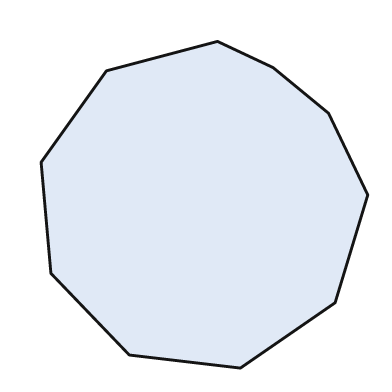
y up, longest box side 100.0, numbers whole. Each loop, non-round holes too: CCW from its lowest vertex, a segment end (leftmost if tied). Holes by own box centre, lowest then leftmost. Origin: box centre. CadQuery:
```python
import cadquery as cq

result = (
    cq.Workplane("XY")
    .moveTo(11.0, -50.0)
    .lineTo(40.0, -30.0)
    .lineTo(50.0, 3.0)
    .lineTo(38.0, 28.0)
    .lineTo(21.0, 42.0)
    .lineTo(4.0, 50.0)
    .lineTo(-30.0, 41.0)
    .lineTo(-50.0, 13.0)
    .lineTo(-47.0, -21.0)
    .lineTo(-23.0, -46.0)
    .close()
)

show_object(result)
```